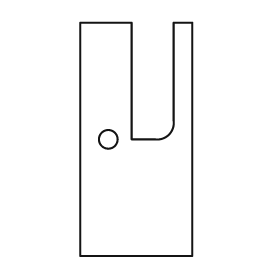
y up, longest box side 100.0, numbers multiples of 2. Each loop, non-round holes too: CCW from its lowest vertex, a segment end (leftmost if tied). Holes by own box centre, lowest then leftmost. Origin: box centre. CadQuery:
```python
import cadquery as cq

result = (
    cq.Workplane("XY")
    .moveTo(-24.0, -50.0)
    .lineTo(24.0, -50.0)
    .lineTo(24.0, 50.0)
    .lineTo(16.0, 50.0)
    .lineTo(16.0, 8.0)
    .threePointArc((14.0, 2.0), (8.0, 0.0))
    .lineTo(-2.0, 0.0)
    .lineTo(-2.0, 50.0)
    .lineTo(-24.0, 50.0)
    .close()
    .moveTo(-12.0, 0.0)
    .circle(4.0)
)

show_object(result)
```